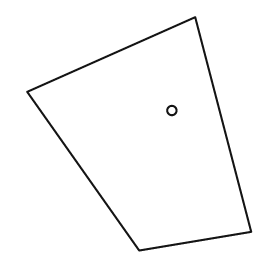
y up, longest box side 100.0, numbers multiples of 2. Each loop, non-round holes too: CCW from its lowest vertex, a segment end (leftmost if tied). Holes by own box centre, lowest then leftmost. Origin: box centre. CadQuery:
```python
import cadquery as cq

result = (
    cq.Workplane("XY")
    .moveTo(0.0, -50.0)
    .lineTo(48.0, -42.0)
    .lineTo(24.0, 50.0)
    .lineTo(-48.0, 18.0)
    .close()
    .moveTo(14.0, 10.0)
    .circle(2.0)
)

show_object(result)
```